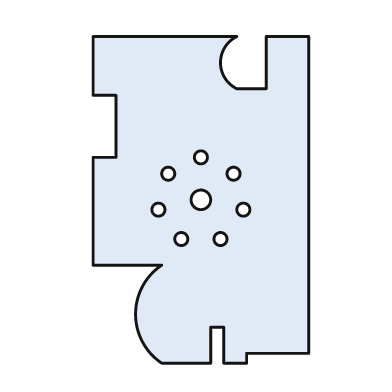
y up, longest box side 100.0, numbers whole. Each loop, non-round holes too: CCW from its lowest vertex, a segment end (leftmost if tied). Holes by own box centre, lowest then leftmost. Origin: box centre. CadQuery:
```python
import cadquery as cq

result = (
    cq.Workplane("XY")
    .moveTo(-12.0, -50.0)
    .lineTo(3.0, -50.0)
    .lineTo(3.0, -39.0)
    .lineTo(7.0, -39.0)
    .lineTo(7.0, -50.0)
    .lineTo(14.0, -50.0)
    .lineTo(14.0, -47.0)
    .lineTo(33.0, -47.0)
    .lineTo(33.0, 50.0)
    .lineTo(20.0, 50.0)
    .lineTo(20.0, 34.0)
    .lineTo(11.0, 34.0)
    .threePointArc((6.0, 42.0), (11.0, 50.0))
    .lineTo(-33.0, 50.0)
    .lineTo(-33.0, 32.0)
    .lineTo(-26.0, 32.0)
    .lineTo(-26.0, 13.0)
    .lineTo(-33.0, 13.0)
    .lineTo(-33.0, -20.0)
    .lineTo(-12.0, -20.0)
    .threePointArc((-20.0, -35.0), (-12.0, -50.0))
    .close()
    .moveTo(-6.0, -12.0)
    .circle(2.0)
    .moveTo(6.0, -12.0)
    .circle(2.0)
    .moveTo(-13.0, -3.0)
    .circle(2.0)
    .moveTo(13.0, -3.0)
    .circle(2.0)
    .moveTo(0.0, 0.0)
    .circle(3.0)
    .moveTo(-10.0, 8.0)
    .circle(2.0)
    .moveTo(10.0, 8.0)
    .circle(2.0)
    .moveTo(0.0, 13.0)
    .circle(2.0)
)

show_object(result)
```